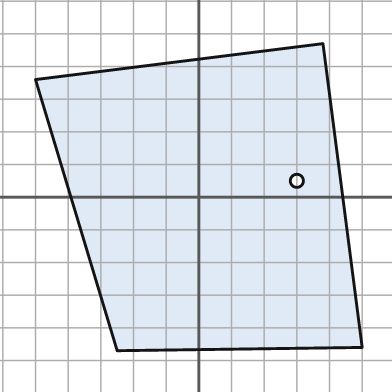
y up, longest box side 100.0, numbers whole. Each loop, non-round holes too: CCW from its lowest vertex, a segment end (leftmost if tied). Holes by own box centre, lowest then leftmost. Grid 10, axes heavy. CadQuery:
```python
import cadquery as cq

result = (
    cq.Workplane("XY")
    .moveTo(-25.0, -47.0)
    .lineTo(50.0, -46.0)
    .lineTo(38.0, 47.0)
    .lineTo(-50.0, 36.0)
    .close()
    .moveTo(30.0, 5.0)
    .circle(2.0)
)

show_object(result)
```